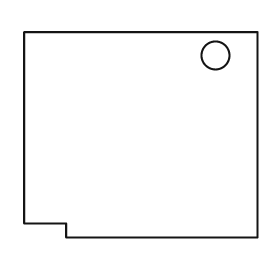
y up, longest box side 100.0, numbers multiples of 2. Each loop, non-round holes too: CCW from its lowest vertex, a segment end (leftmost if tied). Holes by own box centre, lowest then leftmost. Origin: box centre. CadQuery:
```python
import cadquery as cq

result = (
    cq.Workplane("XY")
    .moveTo(-32.0, -44.0)
    .lineTo(50.0, -44.0)
    .lineTo(50.0, 44.0)
    .lineTo(-50.0, 44.0)
    .lineTo(-50.0, -38.0)
    .lineTo(-32.0, -38.0)
    .close()
    .moveTo(32.0, 34.0)
    .circle(6.0)
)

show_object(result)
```